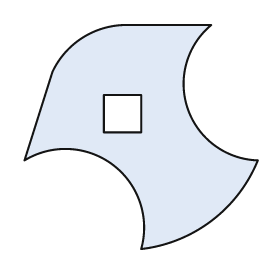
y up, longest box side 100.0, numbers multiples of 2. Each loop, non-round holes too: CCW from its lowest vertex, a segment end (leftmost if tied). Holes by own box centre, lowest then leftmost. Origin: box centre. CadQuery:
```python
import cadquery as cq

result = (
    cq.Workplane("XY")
    .moveTo(0.0, -48.0)
    .threePointArc((30.0, -36.0), (50.0, -10.0))
    .threePointArc((20.0, 12.0), (30.0, 48.0))
    .lineTo(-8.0, 48.0)
    .threePointArc((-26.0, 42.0), (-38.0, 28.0))
    .lineTo(-50.0, -10.0)
    .threePointArc((-12.0, -12.0), (0.0, -48.0))
    .close()
    .moveTo(-16.0, 2.0)
    .lineTo(0.0, 2.0)
    .lineTo(0.0, 18.0)
    .lineTo(-16.0, 18.0)
    .close()
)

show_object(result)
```